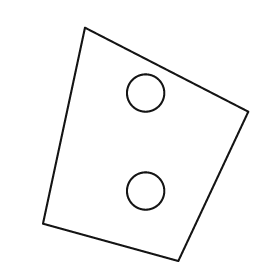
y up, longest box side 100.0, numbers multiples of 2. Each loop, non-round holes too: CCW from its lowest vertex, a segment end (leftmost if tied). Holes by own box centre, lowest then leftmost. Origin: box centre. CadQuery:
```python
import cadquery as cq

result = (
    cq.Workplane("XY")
    .moveTo(14.0, -50.0)
    .lineTo(44.0, 14.0)
    .lineTo(-26.0, 50.0)
    .lineTo(-44.0, -34.0)
    .close()
    .moveTo(0.0, -20.0)
    .circle(8.0)
    .moveTo(0.0, 22.0)
    .circle(8.0)
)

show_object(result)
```